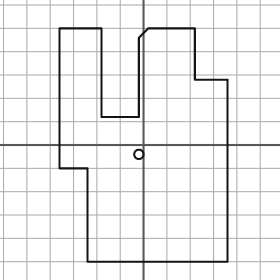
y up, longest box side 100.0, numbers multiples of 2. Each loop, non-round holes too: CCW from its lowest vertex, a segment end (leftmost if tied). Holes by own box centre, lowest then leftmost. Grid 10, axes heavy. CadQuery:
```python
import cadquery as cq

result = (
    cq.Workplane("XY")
    .moveTo(-24.0, -50.0)
    .lineTo(36.0, -50.0)
    .lineTo(36.0, 28.0)
    .lineTo(22.0, 28.0)
    .lineTo(22.0, 50.0)
    .lineTo(2.0, 50.0)
    .lineTo(-2.0, 46.0)
    .lineTo(-2.0, 12.0)
    .lineTo(-18.0, 12.0)
    .lineTo(-18.0, 50.0)
    .lineTo(-36.0, 50.0)
    .lineTo(-36.0, -10.0)
    .lineTo(-24.0, -10.0)
    .close()
    .moveTo(-2.0, -4.0)
    .circle(2.0)
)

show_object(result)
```